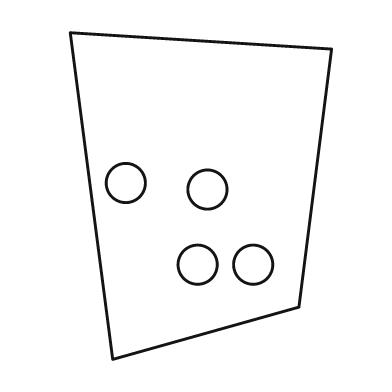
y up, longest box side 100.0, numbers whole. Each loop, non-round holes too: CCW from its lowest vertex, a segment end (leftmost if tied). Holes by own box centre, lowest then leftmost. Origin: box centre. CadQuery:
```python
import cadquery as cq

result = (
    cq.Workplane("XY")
    .moveTo(-27.0, -50.0)
    .lineTo(30.0, -34.0)
    .lineTo(40.0, 45.0)
    .lineTo(-40.0, 50.0)
    .close()
    .moveTo(-1.0, -21.0)
    .circle(6.0)
    .moveTo(16.0, -21.0)
    .circle(6.0)
    .moveTo(2.0, 2.0)
    .circle(6.0)
    .moveTo(-23.0, 4.0)
    .circle(6.0)
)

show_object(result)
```